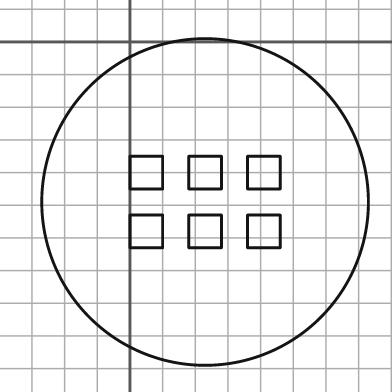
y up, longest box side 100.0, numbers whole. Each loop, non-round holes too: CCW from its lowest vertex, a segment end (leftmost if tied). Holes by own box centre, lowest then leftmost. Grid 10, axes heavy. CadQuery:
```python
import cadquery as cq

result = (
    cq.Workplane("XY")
    .moveTo(23.0, -49.0)
    .circle(50.0)
    .moveTo(0.0, -63.0)
    .lineTo(10.0, -63.0)
    .lineTo(10.0, -53.0)
    .lineTo(0.0, -53.0)
    .close()
    .moveTo(18.0, -63.0)
    .lineTo(28.0, -63.0)
    .lineTo(28.0, -53.0)
    .lineTo(18.0, -53.0)
    .close()
    .moveTo(36.0, -63.0)
    .lineTo(46.0, -63.0)
    .lineTo(46.0, -53.0)
    .lineTo(36.0, -53.0)
    .close()
    .moveTo(0.0, -45.0)
    .lineTo(10.0, -45.0)
    .lineTo(10.0, -35.0)
    .lineTo(0.0, -35.0)
    .close()
    .moveTo(18.0, -45.0)
    .lineTo(28.0, -45.0)
    .lineTo(28.0, -35.0)
    .lineTo(18.0, -35.0)
    .close()
    .moveTo(36.0, -45.0)
    .lineTo(46.0, -45.0)
    .lineTo(46.0, -35.0)
    .lineTo(36.0, -35.0)
    .close()
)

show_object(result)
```